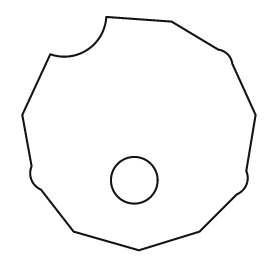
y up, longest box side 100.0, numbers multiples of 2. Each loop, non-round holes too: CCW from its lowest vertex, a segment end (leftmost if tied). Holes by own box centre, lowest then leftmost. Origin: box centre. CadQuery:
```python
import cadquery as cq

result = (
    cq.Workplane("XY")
    .moveTo(0.0, -50.0)
    .lineTo(26.0, -42.0)
    .lineTo(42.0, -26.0)
    .threePointArc((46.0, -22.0), (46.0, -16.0))
    .lineTo(50.0, 8.0)
    .lineTo(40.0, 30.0)
    .threePointArc((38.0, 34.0), (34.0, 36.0))
    .lineTo(14.0, 48.0)
    .lineTo(-14.0, 50.0)
    .threePointArc((-22.0, 36.0), (-38.0, 34.0))
    .lineTo(-50.0, 8.0)
    .lineTo(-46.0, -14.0)
    .threePointArc((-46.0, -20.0), (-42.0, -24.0))
    .lineTo(-28.0, -42.0)
    .close()
    .moveTo(-2.0, -20.0)
    .circle(10.0)
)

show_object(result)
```